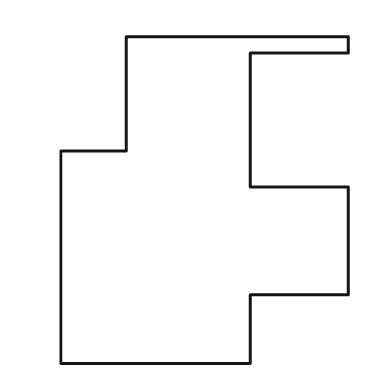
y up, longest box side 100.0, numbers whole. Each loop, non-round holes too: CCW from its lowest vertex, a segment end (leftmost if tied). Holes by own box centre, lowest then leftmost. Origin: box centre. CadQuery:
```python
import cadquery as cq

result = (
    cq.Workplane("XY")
    .moveTo(-44.0, -50.0)
    .lineTo(14.0, -50.0)
    .lineTo(14.0, -29.0)
    .lineTo(44.0, -29.0)
    .lineTo(44.0, 4.0)
    .lineTo(14.0, 4.0)
    .lineTo(14.0, 45.0)
    .lineTo(44.0, 45.0)
    .lineTo(44.0, 50.0)
    .lineTo(-24.0, 50.0)
    .lineTo(-24.0, 15.0)
    .lineTo(-44.0, 15.0)
    .close()
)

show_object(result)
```